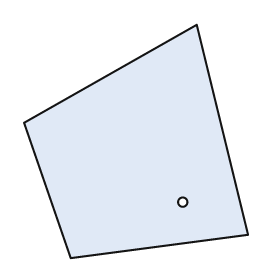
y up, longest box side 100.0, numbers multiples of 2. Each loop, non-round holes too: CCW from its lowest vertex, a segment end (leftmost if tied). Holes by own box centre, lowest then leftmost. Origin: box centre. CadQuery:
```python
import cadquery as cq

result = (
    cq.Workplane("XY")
    .moveTo(-28.0, -50.0)
    .lineTo(48.0, -40.0)
    .lineTo(26.0, 50.0)
    .lineTo(-48.0, 8.0)
    .close()
    .moveTo(20.0, -26.0)
    .circle(2.0)
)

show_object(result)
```